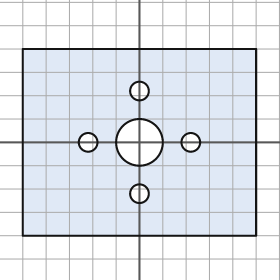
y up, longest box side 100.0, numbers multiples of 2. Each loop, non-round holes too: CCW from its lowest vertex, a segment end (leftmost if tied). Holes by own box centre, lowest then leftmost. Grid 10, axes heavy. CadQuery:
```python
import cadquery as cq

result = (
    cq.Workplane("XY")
    .moveTo(-50.0, -40.0)
    .lineTo(50.0, -40.0)
    .lineTo(50.0, 40.0)
    .lineTo(-50.0, 40.0)
    .close()
    .moveTo(0.0, -22.0)
    .circle(4.0)
    .moveTo(-22.0, 0.0)
    .circle(4.0)
    .moveTo(0.0, 0.0)
    .circle(10.0)
    .moveTo(22.0, 0.0)
    .circle(4.0)
    .moveTo(0.0, 22.0)
    .circle(4.0)
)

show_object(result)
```